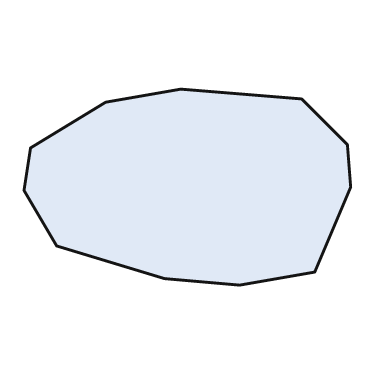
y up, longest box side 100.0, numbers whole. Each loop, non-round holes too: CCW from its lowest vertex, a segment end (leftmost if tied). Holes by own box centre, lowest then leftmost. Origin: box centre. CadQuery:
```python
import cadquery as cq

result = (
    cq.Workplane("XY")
    .moveTo(16.0, -30.0)
    .lineTo(39.0, -26.0)
    .lineTo(50.0, 0.0)
    .lineTo(49.0, 13.0)
    .lineTo(35.0, 27.0)
    .lineTo(-2.0, 30.0)
    .lineTo(-25.0, 26.0)
    .lineTo(-48.0, 12.0)
    .lineTo(-50.0, -1.0)
    .lineTo(-40.0, -18.0)
    .lineTo(-7.0, -28.0)
    .close()
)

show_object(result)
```